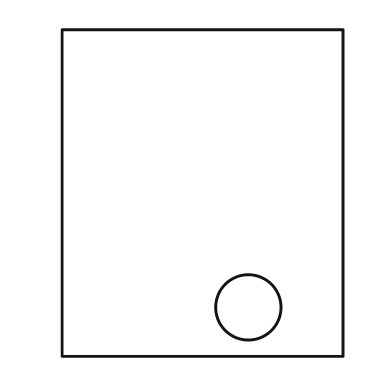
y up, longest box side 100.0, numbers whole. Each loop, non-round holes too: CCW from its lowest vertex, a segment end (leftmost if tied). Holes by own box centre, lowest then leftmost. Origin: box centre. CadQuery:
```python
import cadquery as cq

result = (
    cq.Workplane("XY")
    .moveTo(-43.0, -50.0)
    .lineTo(43.0, -50.0)
    .lineTo(43.0, 50.0)
    .lineTo(-43.0, 50.0)
    .close()
    .moveTo(14.0, -35.0)
    .circle(10.0)
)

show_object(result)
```